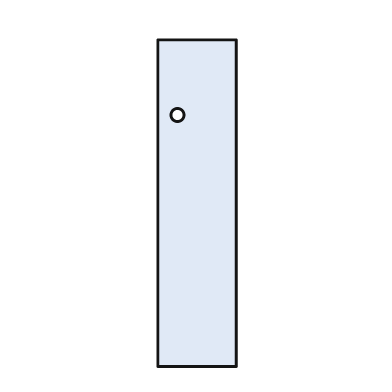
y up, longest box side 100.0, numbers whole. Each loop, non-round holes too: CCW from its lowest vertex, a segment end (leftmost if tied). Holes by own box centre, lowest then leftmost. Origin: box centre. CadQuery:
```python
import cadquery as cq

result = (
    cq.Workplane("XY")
    .moveTo(-12.0, -50.0)
    .lineTo(12.0, -50.0)
    .lineTo(12.0, 50.0)
    .lineTo(-12.0, 50.0)
    .close()
    .moveTo(-6.0, 27.0)
    .circle(2.0)
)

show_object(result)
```